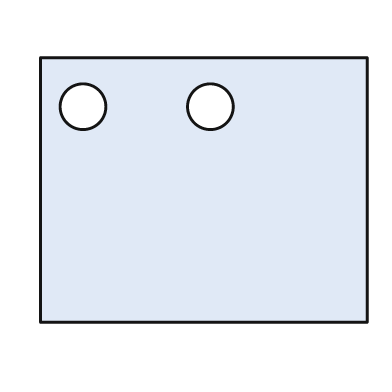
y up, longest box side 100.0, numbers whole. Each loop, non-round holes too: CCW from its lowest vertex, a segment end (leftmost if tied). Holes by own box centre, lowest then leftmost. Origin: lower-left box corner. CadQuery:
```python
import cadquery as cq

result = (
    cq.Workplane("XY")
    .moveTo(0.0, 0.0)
    .lineTo(100.0, 0.0)
    .lineTo(100.0, 81.0)
    .lineTo(0.0, 81.0)
    .close()
    .moveTo(13.0, 66.0)
    .circle(7.0)
    .moveTo(52.0, 66.0)
    .circle(7.0)
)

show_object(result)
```